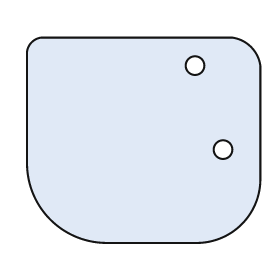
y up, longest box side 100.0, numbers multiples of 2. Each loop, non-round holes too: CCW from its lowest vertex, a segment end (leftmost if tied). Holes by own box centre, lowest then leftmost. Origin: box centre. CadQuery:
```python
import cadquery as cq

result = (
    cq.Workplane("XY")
    .moveTo(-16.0, -44.0)
    .lineTo(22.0, -44.0)
    .threePointArc((42.0, -36.0), (50.0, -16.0))
    .lineTo(50.0, 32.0)
    .threePointArc((46.0, 40.0), (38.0, 44.0))
    .lineTo(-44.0, 44.0)
    .threePointArc((-48.0, 42.0), (-50.0, 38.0))
    .lineTo(-50.0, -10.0)
    .threePointArc((-40.0, -34.0), (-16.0, -44.0))
    .close()
    .moveTo(34.0, -4.0)
    .circle(4.0)
    .moveTo(22.0, 32.0)
    .circle(4.0)
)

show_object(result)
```